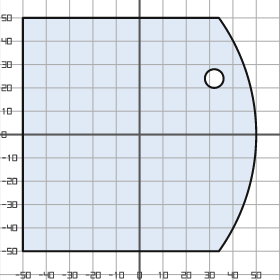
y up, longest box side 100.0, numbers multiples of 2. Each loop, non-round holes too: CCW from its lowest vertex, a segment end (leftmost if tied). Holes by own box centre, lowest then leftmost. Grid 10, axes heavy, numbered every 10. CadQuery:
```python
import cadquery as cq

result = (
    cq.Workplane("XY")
    .moveTo(-50.0, -50.0)
    .lineTo(34.0, -50.0)
    .threePointArc((50.0, 0.0), (34.0, 50.0))
    .lineTo(-50.0, 50.0)
    .close()
    .moveTo(32.0, 24.0)
    .circle(4.0)
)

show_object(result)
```